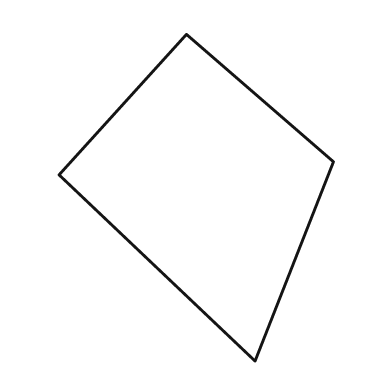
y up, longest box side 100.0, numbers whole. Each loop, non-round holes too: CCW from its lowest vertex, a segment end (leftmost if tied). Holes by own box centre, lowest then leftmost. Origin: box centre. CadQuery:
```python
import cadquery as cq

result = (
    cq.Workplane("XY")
    .moveTo(18.0, -50.0)
    .lineTo(42.0, 11.0)
    .lineTo(-3.0, 50.0)
    .lineTo(-42.0, 7.0)
    .close()
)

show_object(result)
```